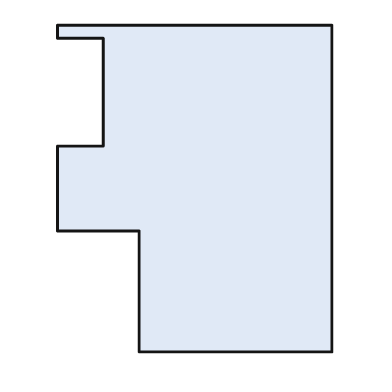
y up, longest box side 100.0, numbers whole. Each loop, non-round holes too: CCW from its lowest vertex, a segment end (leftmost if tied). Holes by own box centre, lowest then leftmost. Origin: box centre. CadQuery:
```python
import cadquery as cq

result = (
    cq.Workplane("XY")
    .moveTo(-17.0, -50.0)
    .lineTo(42.0, -50.0)
    .lineTo(42.0, 50.0)
    .lineTo(-42.0, 50.0)
    .lineTo(-42.0, 46.0)
    .lineTo(-28.0, 46.0)
    .lineTo(-28.0, 13.0)
    .lineTo(-42.0, 13.0)
    .lineTo(-42.0, -13.0)
    .lineTo(-17.0, -13.0)
    .close()
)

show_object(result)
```